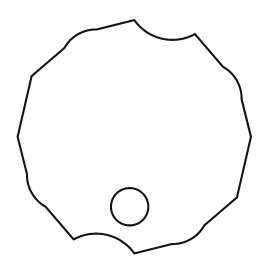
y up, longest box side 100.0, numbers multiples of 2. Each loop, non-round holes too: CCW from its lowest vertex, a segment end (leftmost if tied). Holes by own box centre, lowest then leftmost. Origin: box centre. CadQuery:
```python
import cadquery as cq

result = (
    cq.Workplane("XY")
    .moveTo(0.0, -50.0)
    .lineTo(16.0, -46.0)
    .threePointArc((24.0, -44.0), (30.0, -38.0))
    .lineTo(44.0, -26.0)
    .lineTo(50.0, 0.0)
    .lineTo(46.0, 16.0)
    .threePointArc((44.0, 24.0), (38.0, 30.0))
    .lineTo(26.0, 44.0)
    .threePointArc((12.0, 42.0), (0.0, 50.0))
    .lineTo(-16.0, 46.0)
    .threePointArc((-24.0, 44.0), (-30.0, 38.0))
    .lineTo(-44.0, 26.0)
    .lineTo(-50.0, 0.0)
    .lineTo(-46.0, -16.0)
    .threePointArc((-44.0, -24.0), (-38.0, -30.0))
    .lineTo(-26.0, -44.0)
    .threePointArc((-12.0, -42.0), (0.0, -50.0))
    .close()
    .moveTo(-2.0, -30.0)
    .circle(8.0)
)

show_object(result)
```